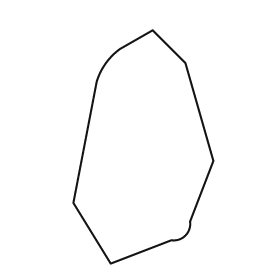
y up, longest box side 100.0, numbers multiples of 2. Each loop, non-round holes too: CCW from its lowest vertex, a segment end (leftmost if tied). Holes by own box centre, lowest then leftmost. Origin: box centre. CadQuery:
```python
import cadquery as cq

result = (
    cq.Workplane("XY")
    .moveTo(-14.0, -50.0)
    .lineTo(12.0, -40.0)
    .threePointArc((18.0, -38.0), (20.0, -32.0))
    .lineTo(30.0, -6.0)
    .lineTo(18.0, 36.0)
    .lineTo(4.0, 50.0)
    .lineTo(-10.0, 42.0)
    .threePointArc((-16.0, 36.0), (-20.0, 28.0))
    .lineTo(-30.0, -24.0)
    .close()
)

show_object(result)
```